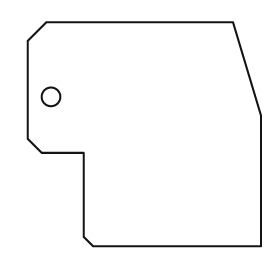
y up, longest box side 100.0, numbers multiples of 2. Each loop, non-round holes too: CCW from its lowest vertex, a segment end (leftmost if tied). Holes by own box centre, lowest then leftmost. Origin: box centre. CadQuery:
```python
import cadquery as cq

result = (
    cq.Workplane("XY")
    .moveTo(-22.0, -48.0)
    .lineTo(50.0, -48.0)
    .lineTo(50.0, 8.0)
    .lineTo(38.0, 48.0)
    .lineTo(-42.0, 48.0)
    .lineTo(-50.0, 40.0)
    .lineTo(-50.0, -2.0)
    .lineTo(-44.0, -8.0)
    .lineTo(-26.0, -8.0)
    .lineTo(-26.0, -44.0)
    .close()
    .moveTo(-40.0, 16.0)
    .circle(4.0)
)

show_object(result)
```